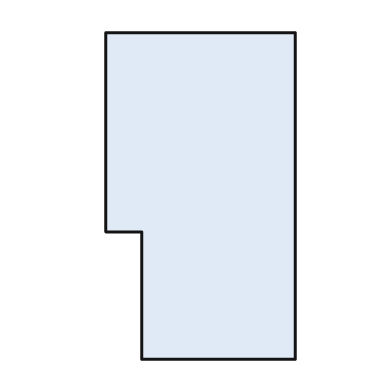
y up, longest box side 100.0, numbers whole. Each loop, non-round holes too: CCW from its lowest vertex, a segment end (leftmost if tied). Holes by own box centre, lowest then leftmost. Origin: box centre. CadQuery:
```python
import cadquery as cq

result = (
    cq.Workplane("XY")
    .moveTo(-18.0, -50.0)
    .lineTo(29.0, -50.0)
    .lineTo(29.0, 50.0)
    .lineTo(-29.0, 50.0)
    .lineTo(-29.0, -11.0)
    .lineTo(-18.0, -11.0)
    .close()
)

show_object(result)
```